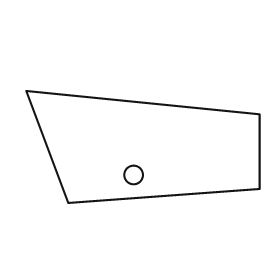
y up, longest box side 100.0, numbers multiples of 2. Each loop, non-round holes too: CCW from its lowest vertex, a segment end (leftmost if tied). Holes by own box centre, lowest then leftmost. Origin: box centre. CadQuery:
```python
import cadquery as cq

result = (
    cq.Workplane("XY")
    .moveTo(-32.0, -24.0)
    .lineTo(50.0, -18.0)
    .lineTo(50.0, 14.0)
    .lineTo(-50.0, 24.0)
    .close()
    .moveTo(-4.0, -12.0)
    .circle(4.0)
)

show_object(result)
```